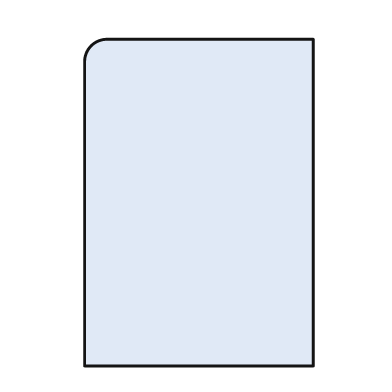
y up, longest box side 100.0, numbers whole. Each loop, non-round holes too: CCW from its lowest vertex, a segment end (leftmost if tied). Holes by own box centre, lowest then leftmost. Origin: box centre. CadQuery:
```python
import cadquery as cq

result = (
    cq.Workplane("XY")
    .moveTo(-35.0, -50.0)
    .lineTo(35.0, -50.0)
    .lineTo(35.0, 50.0)
    .lineTo(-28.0, 50.0)
    .threePointArc((-33.0, 48.0), (-35.0, 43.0))
    .close()
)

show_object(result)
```